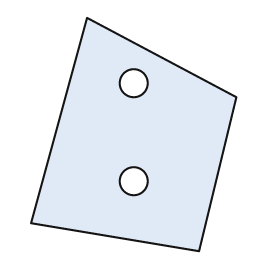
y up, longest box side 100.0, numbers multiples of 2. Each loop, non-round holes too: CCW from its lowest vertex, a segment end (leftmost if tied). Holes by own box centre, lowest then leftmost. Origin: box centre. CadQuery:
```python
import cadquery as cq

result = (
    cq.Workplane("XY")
    .moveTo(28.0, -50.0)
    .lineTo(44.0, 16.0)
    .lineTo(-20.0, 50.0)
    .lineTo(-44.0, -38.0)
    .close()
    .moveTo(0.0, -20.0)
    .circle(6.0)
    .moveTo(0.0, 22.0)
    .circle(6.0)
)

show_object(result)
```